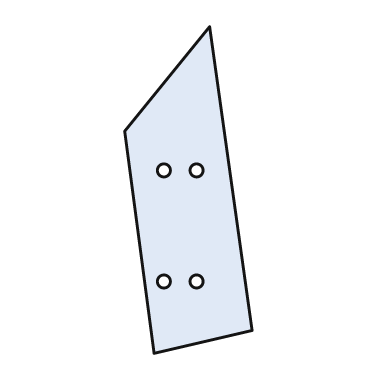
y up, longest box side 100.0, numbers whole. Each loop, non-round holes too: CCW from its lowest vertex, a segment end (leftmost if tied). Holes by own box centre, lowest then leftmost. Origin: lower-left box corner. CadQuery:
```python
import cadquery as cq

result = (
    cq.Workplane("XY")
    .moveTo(9.0, 0.0)
    .lineTo(39.0, 7.0)
    .lineTo(26.0, 100.0)
    .lineTo(0.0, 68.0)
    .close()
    .moveTo(12.0, 22.0)
    .circle(2.0)
    .moveTo(22.0, 22.0)
    .circle(2.0)
    .moveTo(12.0, 56.0)
    .circle(2.0)
    .moveTo(22.0, 56.0)
    .circle(2.0)
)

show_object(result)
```